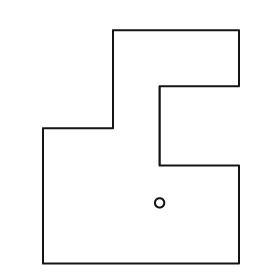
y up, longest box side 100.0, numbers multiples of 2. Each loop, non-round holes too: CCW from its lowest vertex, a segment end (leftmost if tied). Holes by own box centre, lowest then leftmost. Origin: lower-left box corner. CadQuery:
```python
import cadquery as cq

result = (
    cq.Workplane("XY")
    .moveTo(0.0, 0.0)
    .lineTo(84.0, 0.0)
    .lineTo(84.0, 42.0)
    .lineTo(50.0, 42.0)
    .lineTo(50.0, 76.0)
    .lineTo(84.0, 76.0)
    .lineTo(84.0, 100.0)
    .lineTo(30.0, 100.0)
    .lineTo(30.0, 58.0)
    .lineTo(0.0, 58.0)
    .close()
    .moveTo(50.0, 26.0)
    .circle(2.0)
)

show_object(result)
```